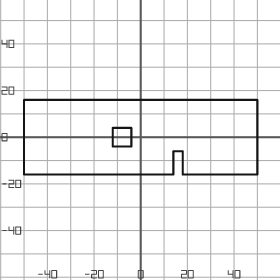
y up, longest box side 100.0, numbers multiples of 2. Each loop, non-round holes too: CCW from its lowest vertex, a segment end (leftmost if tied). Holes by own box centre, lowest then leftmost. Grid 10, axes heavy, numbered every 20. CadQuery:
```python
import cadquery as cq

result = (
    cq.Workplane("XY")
    .moveTo(-50.0, -16.0)
    .lineTo(14.0, -16.0)
    .lineTo(14.0, -6.0)
    .lineTo(18.0, -6.0)
    .lineTo(18.0, -16.0)
    .lineTo(50.0, -16.0)
    .lineTo(50.0, 16.0)
    .lineTo(-50.0, 16.0)
    .close()
    .moveTo(-12.0, -4.0)
    .lineTo(-4.0, -4.0)
    .lineTo(-4.0, 4.0)
    .lineTo(-12.0, 4.0)
    .close()
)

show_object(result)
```